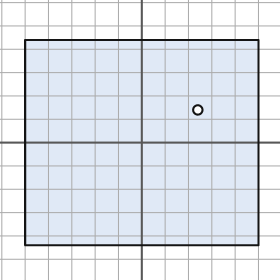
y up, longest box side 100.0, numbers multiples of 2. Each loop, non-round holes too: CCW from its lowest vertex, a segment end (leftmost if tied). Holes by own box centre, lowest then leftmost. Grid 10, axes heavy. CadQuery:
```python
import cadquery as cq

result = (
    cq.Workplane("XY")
    .moveTo(-50.0, -44.0)
    .lineTo(50.0, -44.0)
    .lineTo(50.0, 44.0)
    .lineTo(-50.0, 44.0)
    .close()
    .moveTo(24.0, 14.0)
    .circle(2.0)
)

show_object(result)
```